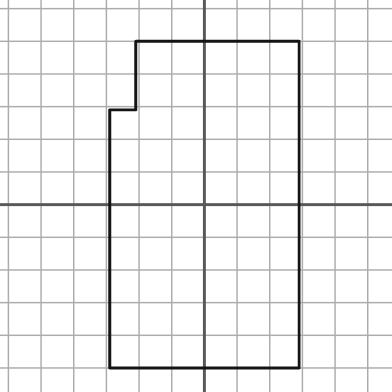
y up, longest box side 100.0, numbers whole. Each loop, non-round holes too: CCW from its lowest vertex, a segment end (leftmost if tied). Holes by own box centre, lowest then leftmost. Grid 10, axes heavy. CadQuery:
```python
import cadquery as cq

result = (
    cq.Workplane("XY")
    .moveTo(-29.0, -50.0)
    .lineTo(29.0, -50.0)
    .lineTo(29.0, 50.0)
    .lineTo(-21.0, 50.0)
    .lineTo(-21.0, 29.0)
    .lineTo(-29.0, 29.0)
    .close()
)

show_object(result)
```